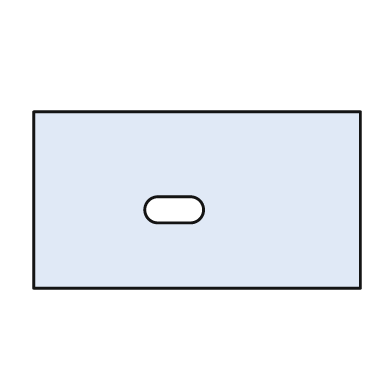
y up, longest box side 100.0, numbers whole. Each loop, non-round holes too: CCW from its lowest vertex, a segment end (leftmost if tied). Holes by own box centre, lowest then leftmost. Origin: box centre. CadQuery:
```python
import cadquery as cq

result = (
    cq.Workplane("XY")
    .moveTo(-50.0, -27.0)
    .lineTo(50.0, -27.0)
    .lineTo(50.0, 27.0)
    .lineTo(-50.0, 27.0)
    .close()
    .moveTo(-12.0, -7.0)
    .lineTo(-2.0, -7.0)
    .threePointArc((2.0, -3.0), (-2.0, 1.0))
    .lineTo(-12.0, 1.0)
    .threePointArc((-16.0, -3.0), (-12.0, -7.0))
    .close()
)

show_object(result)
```